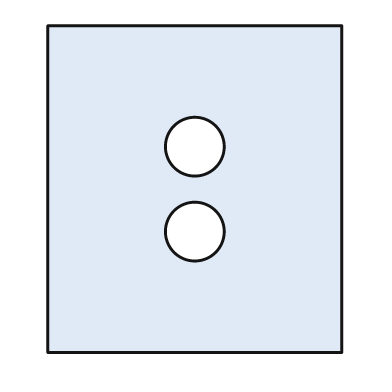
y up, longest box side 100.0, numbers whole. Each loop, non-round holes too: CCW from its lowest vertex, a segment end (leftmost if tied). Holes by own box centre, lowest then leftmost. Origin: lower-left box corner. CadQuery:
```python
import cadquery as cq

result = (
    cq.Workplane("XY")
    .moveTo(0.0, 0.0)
    .lineTo(90.0, 0.0)
    .lineTo(90.0, 100.0)
    .lineTo(0.0, 100.0)
    .close()
    .moveTo(45.0, 37.0)
    .circle(9.0)
    .moveTo(45.0, 63.0)
    .circle(9.0)
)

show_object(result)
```